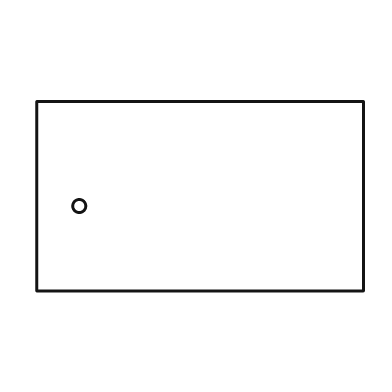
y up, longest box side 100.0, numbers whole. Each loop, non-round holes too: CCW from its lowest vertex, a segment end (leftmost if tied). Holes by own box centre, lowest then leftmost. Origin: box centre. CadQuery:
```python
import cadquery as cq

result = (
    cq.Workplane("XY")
    .moveTo(-50.0, -29.0)
    .lineTo(50.0, -29.0)
    .lineTo(50.0, 29.0)
    .lineTo(-50.0, 29.0)
    .close()
    .moveTo(-37.0, -3.0)
    .circle(2.0)
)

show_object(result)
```